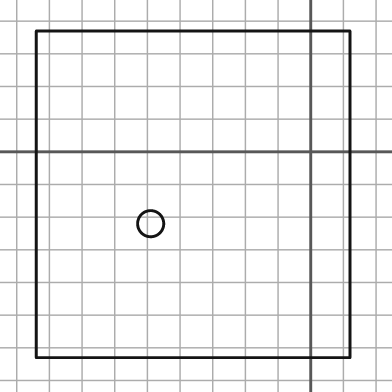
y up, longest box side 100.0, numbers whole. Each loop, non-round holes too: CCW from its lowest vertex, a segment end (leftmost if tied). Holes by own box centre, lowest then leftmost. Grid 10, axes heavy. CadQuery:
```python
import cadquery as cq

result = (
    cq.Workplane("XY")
    .moveTo(-84.0, -63.0)
    .lineTo(12.0, -63.0)
    .lineTo(12.0, 37.0)
    .lineTo(-84.0, 37.0)
    .close()
    .moveTo(-49.0, -22.0)
    .circle(4.0)
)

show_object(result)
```